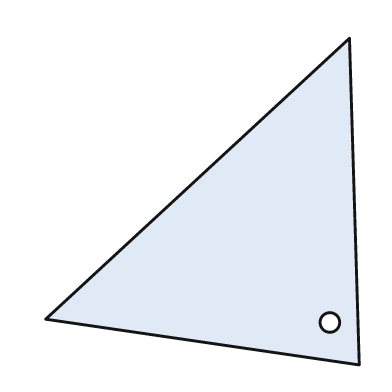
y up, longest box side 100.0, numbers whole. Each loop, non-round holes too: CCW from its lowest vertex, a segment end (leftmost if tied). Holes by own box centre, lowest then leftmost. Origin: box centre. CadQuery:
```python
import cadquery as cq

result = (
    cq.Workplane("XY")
    .moveTo(48.0, -50.0)
    .lineTo(45.0, 50.0)
    .lineTo(-48.0, -36.0)
    .close()
    .moveTo(39.0, -37.0)
    .circle(3.0)
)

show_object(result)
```